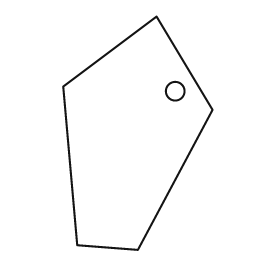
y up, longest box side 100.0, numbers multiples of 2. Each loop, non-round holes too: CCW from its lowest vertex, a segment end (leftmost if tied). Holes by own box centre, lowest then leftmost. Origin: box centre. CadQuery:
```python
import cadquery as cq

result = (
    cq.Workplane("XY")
    .moveTo(0.0, -50.0)
    .lineTo(32.0, 10.0)
    .lineTo(8.0, 50.0)
    .lineTo(-32.0, 20.0)
    .lineTo(-26.0, -48.0)
    .close()
    .moveTo(16.0, 18.0)
    .circle(4.0)
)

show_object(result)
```